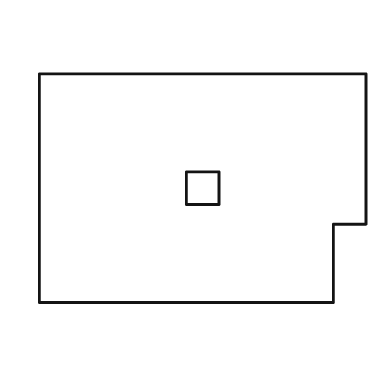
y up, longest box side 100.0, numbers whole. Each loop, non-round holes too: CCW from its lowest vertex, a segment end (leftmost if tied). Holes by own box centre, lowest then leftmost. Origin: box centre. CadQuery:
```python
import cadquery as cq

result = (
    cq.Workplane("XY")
    .moveTo(-50.0, -35.0)
    .lineTo(40.0, -35.0)
    .lineTo(40.0, -11.0)
    .lineTo(50.0, -11.0)
    .lineTo(50.0, 35.0)
    .lineTo(-50.0, 35.0)
    .close()
    .moveTo(-5.0, -5.0)
    .lineTo(5.0, -5.0)
    .lineTo(5.0, 5.0)
    .lineTo(-5.0, 5.0)
    .close()
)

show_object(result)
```